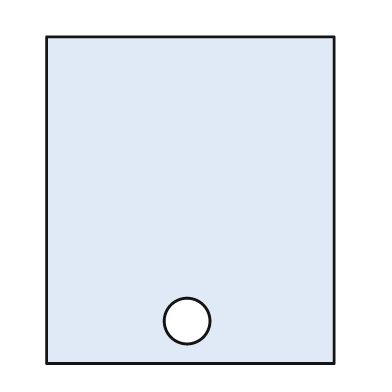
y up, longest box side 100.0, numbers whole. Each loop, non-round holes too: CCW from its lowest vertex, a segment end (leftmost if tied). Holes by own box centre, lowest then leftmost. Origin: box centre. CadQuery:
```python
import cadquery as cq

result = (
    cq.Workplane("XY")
    .moveTo(-44.0, -50.0)
    .lineTo(44.0, -50.0)
    .lineTo(44.0, 50.0)
    .lineTo(-44.0, 50.0)
    .close()
    .moveTo(-1.0, -37.0)
    .circle(7.0)
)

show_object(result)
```